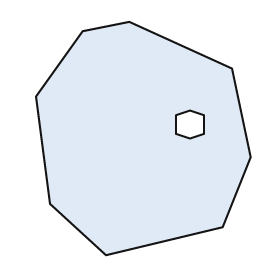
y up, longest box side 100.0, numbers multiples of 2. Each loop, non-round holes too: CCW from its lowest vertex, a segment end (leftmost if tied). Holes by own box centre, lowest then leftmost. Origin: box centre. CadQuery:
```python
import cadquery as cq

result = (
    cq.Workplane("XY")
    .moveTo(-16.0, -50.0)
    .lineTo(34.0, -38.0)
    .lineTo(46.0, -8.0)
    .lineTo(38.0, 30.0)
    .lineTo(-6.0, 50.0)
    .lineTo(-26.0, 46.0)
    .lineTo(-46.0, 18.0)
    .lineTo(-40.0, -28.0)
    .close()
    .moveTo(20.0, 0.0)
    .lineTo(26.0, 2.0)
    .lineTo(26.0, 10.0)
    .lineTo(20.0, 12.0)
    .lineTo(14.0, 10.0)
    .lineTo(14.0, 2.0)
    .close()
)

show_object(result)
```